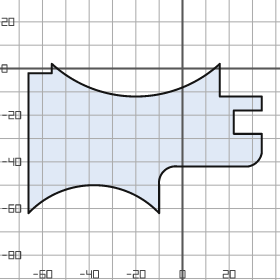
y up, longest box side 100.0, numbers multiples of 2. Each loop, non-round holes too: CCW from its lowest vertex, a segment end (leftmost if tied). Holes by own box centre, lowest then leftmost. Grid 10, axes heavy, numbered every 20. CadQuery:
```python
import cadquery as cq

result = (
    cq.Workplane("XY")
    .moveTo(-66.0, -62.0)
    .threePointArc((-38.0, -50.0), (-10.0, -62.0))
    .lineTo(-10.0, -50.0)
    .threePointArc((-8.0, -44.0), (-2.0, -42.0))
    .lineTo(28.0, -42.0)
    .threePointArc((32.0, -40.0), (34.0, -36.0))
    .lineTo(34.0, -28.0)
    .lineTo(22.0, -28.0)
    .lineTo(22.0, -18.0)
    .lineTo(34.0, -18.0)
    .lineTo(34.0, -12.0)
    .lineTo(16.0, -12.0)
    .lineTo(16.0, 2.0)
    .threePointArc((-20.0, -12.0), (-56.0, 2.0))
    .lineTo(-56.0, -2.0)
    .lineTo(-66.0, -2.0)
    .close()
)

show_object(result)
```